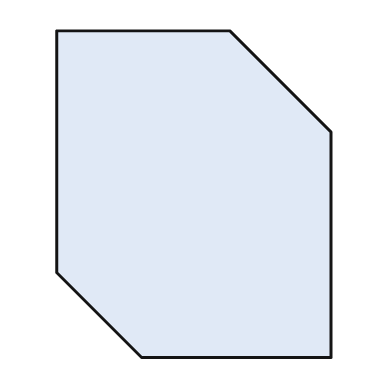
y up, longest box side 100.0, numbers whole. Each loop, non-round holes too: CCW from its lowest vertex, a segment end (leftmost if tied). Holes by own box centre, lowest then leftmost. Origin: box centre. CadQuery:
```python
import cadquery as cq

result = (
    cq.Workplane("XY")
    .moveTo(-16.0, -50.0)
    .lineTo(42.0, -50.0)
    .lineTo(42.0, 19.0)
    .lineTo(11.0, 50.0)
    .lineTo(-42.0, 50.0)
    .lineTo(-42.0, -24.0)
    .close()
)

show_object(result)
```